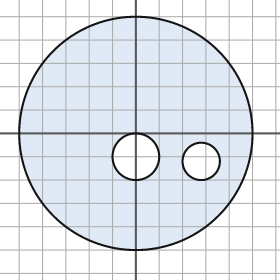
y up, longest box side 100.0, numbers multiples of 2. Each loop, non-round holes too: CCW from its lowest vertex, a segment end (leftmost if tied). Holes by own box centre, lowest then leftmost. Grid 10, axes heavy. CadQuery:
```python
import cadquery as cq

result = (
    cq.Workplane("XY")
    .moveTo(0.0, 0.0)
    .circle(50.0)
    .moveTo(28.0, -12.0)
    .circle(8.0)
    .moveTo(0.0, -10.0)
    .circle(10.0)
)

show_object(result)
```